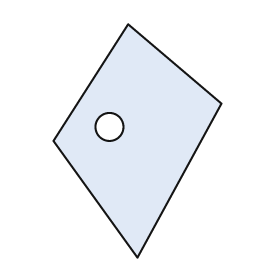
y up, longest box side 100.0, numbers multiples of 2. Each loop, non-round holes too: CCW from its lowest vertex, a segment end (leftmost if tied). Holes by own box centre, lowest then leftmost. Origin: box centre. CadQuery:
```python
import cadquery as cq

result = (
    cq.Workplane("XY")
    .moveTo(0.0, -50.0)
    .lineTo(36.0, 16.0)
    .lineTo(-4.0, 50.0)
    .lineTo(-36.0, 0.0)
    .close()
    .moveTo(-12.0, 6.0)
    .circle(6.0)
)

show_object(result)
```